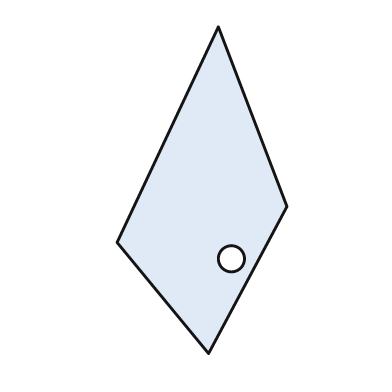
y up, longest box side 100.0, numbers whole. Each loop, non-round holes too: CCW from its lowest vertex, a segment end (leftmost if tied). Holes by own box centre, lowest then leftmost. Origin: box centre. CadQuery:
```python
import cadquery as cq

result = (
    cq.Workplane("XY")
    .moveTo(2.0, -50.0)
    .lineTo(26.0, -5.0)
    .lineTo(5.0, 50.0)
    .lineTo(-26.0, -16.0)
    .close()
    .moveTo(9.0, -21.0)
    .circle(4.0)
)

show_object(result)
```